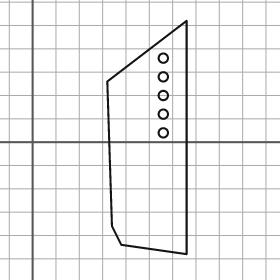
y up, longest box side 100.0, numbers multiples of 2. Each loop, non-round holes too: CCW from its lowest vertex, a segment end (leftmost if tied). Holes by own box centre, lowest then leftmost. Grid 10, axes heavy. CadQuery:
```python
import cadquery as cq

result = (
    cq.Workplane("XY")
    .moveTo(66.0, -48.0)
    .lineTo(66.0, 52.0)
    .lineTo(32.0, 26.0)
    .lineTo(34.0, -36.0)
    .lineTo(38.0, -44.0)
    .close()
    .moveTo(56.0, 4.0)
    .circle(2.0)
    .moveTo(56.0, 12.0)
    .circle(2.0)
    .moveTo(56.0, 20.0)
    .circle(2.0)
    .moveTo(56.0, 28.0)
    .circle(2.0)
    .moveTo(56.0, 36.0)
    .circle(2.0)
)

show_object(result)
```